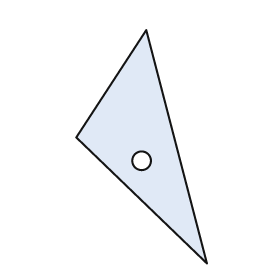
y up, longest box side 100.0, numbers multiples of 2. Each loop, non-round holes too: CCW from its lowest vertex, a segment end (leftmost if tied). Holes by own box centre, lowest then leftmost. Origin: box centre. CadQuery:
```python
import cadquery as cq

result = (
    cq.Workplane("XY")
    .moveTo(28.0, -50.0)
    .lineTo(2.0, 50.0)
    .lineTo(-28.0, 4.0)
    .close()
    .moveTo(0.0, -6.0)
    .circle(4.0)
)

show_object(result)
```